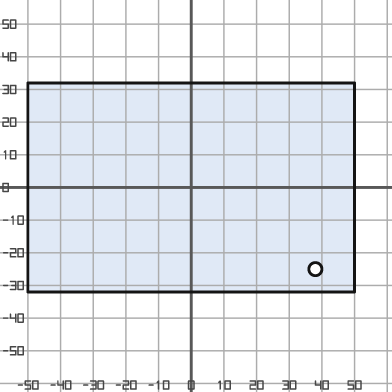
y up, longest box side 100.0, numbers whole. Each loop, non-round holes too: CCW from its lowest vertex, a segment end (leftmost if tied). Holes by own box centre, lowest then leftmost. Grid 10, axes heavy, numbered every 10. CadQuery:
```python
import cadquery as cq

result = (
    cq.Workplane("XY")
    .moveTo(-50.0, -32.0)
    .lineTo(50.0, -32.0)
    .lineTo(50.0, 32.0)
    .lineTo(-50.0, 32.0)
    .close()
    .moveTo(38.0, -25.0)
    .circle(2.0)
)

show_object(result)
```